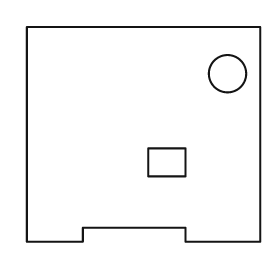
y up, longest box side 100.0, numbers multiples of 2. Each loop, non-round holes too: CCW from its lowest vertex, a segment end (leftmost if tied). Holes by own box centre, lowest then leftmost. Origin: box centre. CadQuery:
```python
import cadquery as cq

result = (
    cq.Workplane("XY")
    .moveTo(-50.0, -46.0)
    .lineTo(-26.0, -46.0)
    .lineTo(-26.0, -40.0)
    .lineTo(18.0, -40.0)
    .lineTo(18.0, -46.0)
    .lineTo(50.0, -46.0)
    .lineTo(50.0, 46.0)
    .lineTo(-50.0, 46.0)
    .close()
    .moveTo(2.0, -18.0)
    .lineTo(18.0, -18.0)
    .lineTo(18.0, -6.0)
    .lineTo(2.0, -6.0)
    .close()
    .moveTo(36.0, 26.0)
    .circle(8.0)
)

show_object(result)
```